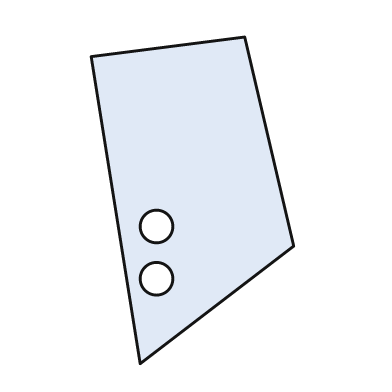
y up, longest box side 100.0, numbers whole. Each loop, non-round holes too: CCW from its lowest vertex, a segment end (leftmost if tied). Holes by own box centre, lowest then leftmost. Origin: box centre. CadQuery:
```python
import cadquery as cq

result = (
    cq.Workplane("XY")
    .moveTo(-16.0, -50.0)
    .lineTo(31.0, -14.0)
    .lineTo(16.0, 50.0)
    .lineTo(-31.0, 44.0)
    .close()
    .moveTo(-11.0, -24.0)
    .circle(5.0)
    .moveTo(-11.0, -8.0)
    .circle(5.0)
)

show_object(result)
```